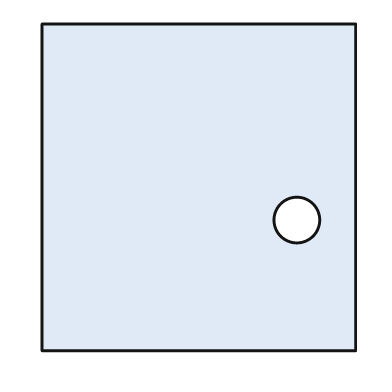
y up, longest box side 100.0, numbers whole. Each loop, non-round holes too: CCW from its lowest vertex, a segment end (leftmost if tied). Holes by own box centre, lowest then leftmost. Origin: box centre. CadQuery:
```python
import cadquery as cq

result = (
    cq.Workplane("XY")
    .moveTo(-48.0, -50.0)
    .lineTo(48.0, -50.0)
    .lineTo(48.0, 50.0)
    .lineTo(-48.0, 50.0)
    .close()
    .moveTo(30.0, -10.0)
    .circle(7.0)
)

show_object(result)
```